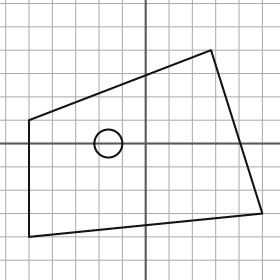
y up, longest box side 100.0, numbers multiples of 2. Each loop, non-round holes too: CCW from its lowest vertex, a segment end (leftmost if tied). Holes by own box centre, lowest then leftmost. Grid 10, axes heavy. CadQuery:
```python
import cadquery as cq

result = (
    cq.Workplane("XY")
    .moveTo(-50.0, -40.0)
    .lineTo(50.0, -30.0)
    .lineTo(28.0, 40.0)
    .lineTo(-50.0, 10.0)
    .close()
    .moveTo(-16.0, 0.0)
    .circle(6.0)
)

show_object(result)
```